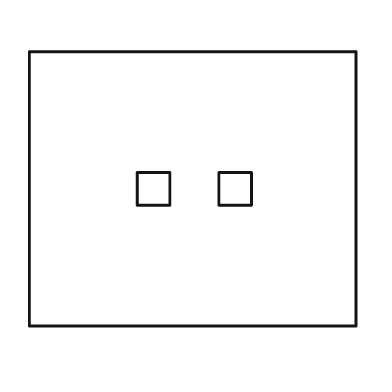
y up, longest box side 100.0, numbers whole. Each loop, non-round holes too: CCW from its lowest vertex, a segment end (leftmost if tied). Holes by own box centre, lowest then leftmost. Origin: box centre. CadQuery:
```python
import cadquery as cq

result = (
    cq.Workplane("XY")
    .moveTo(-50.0, -42.0)
    .lineTo(50.0, -42.0)
    .lineTo(50.0, 42.0)
    .lineTo(-50.0, 42.0)
    .close()
    .moveTo(-17.0, -5.0)
    .lineTo(-7.0, -5.0)
    .lineTo(-7.0, 5.0)
    .lineTo(-17.0, 5.0)
    .close()
    .moveTo(8.0, -5.0)
    .lineTo(18.0, -5.0)
    .lineTo(18.0, 5.0)
    .lineTo(8.0, 5.0)
    .close()
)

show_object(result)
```